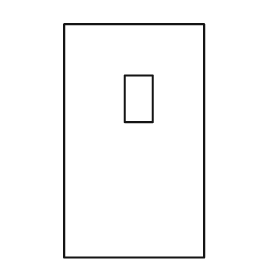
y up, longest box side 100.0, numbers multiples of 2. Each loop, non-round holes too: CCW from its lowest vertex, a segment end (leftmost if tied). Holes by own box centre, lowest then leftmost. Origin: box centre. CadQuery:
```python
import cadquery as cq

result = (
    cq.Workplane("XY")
    .moveTo(-30.0, -50.0)
    .lineTo(30.0, -50.0)
    .lineTo(30.0, 50.0)
    .lineTo(-30.0, 50.0)
    .close()
    .moveTo(-4.0, 8.0)
    .lineTo(8.0, 8.0)
    .lineTo(8.0, 28.0)
    .lineTo(-4.0, 28.0)
    .close()
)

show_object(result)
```